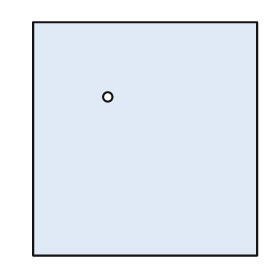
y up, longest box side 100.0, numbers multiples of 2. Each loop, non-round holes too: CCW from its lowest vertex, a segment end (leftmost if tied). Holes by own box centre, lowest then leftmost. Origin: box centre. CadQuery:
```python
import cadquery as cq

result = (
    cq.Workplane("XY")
    .moveTo(-48.0, -50.0)
    .lineTo(48.0, -50.0)
    .lineTo(48.0, 50.0)
    .lineTo(-48.0, 50.0)
    .close()
    .moveTo(-16.0, 18.0)
    .circle(2.0)
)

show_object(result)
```